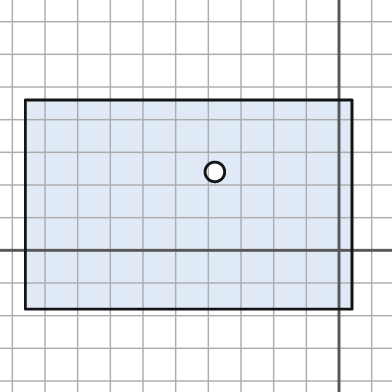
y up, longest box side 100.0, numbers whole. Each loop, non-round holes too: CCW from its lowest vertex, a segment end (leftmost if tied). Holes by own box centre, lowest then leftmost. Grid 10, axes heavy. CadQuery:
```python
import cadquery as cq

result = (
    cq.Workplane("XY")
    .moveTo(-96.0, -18.0)
    .lineTo(4.0, -18.0)
    .lineTo(4.0, 46.0)
    .lineTo(-96.0, 46.0)
    .close()
    .moveTo(-38.0, 24.0)
    .circle(3.0)
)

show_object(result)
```